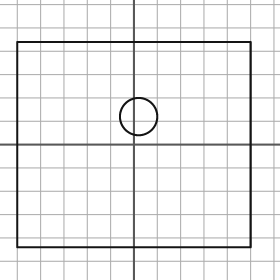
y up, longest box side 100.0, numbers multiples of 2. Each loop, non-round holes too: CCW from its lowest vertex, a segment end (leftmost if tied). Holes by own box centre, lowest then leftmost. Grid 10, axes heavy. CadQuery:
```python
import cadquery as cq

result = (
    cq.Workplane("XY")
    .moveTo(-50.0, -44.0)
    .lineTo(50.0, -44.0)
    .lineTo(50.0, 44.0)
    .lineTo(-50.0, 44.0)
    .close()
    .moveTo(2.0, 12.0)
    .circle(8.0)
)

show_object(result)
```